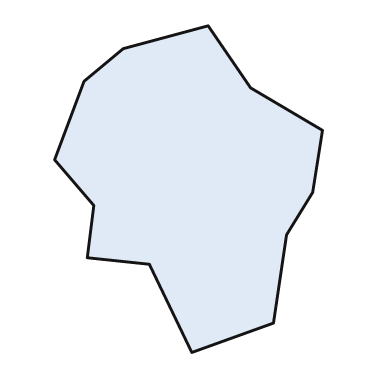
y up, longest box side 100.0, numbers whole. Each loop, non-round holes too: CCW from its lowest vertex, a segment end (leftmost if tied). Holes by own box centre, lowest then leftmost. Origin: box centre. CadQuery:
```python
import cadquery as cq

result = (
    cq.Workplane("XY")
    .moveTo(1.0, -50.0)
    .lineTo(26.0, -41.0)
    .lineTo(30.0, -14.0)
    .lineTo(38.0, -1.0)
    .lineTo(41.0, 18.0)
    .lineTo(19.0, 31.0)
    .lineTo(6.0, 50.0)
    .lineTo(-20.0, 43.0)
    .lineTo(-32.0, 33.0)
    .lineTo(-41.0, 9.0)
    .lineTo(-29.0, -5.0)
    .lineTo(-31.0, -21.0)
    .lineTo(-12.0, -23.0)
    .close()
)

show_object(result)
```